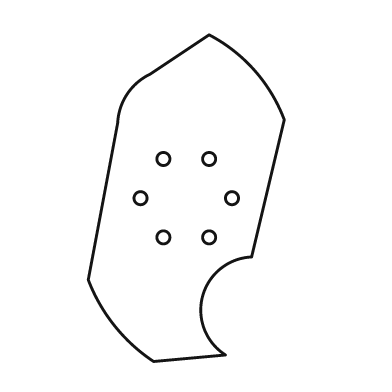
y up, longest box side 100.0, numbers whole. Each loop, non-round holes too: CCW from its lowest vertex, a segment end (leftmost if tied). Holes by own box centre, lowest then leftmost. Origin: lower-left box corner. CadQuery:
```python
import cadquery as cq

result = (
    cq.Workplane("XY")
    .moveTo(20.0, 0.0)
    .lineTo(42.0, 2.0)
    .threePointArc((35.0, 20.0), (50.0, 32.0))
    .lineTo(60.0, 74.0)
    .threePointArc((51.0, 89.0), (37.0, 100.0))
    .lineTo(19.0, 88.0)
    .threePointArc((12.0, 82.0), (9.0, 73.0))
    .lineTo(0.0, 25.0)
    .threePointArc((8.0, 11.0), (20.0, 0.0))
    .close()
    .moveTo(23.0, 38.0)
    .circle(2.0)
    .moveTo(37.0, 38.0)
    .circle(2.0)
    .moveTo(16.0, 50.0)
    .circle(2.0)
    .moveTo(44.0, 50.0)
    .circle(2.0)
    .moveTo(23.0, 62.0)
    .circle(2.0)
    .moveTo(37.0, 62.0)
    .circle(2.0)
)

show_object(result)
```